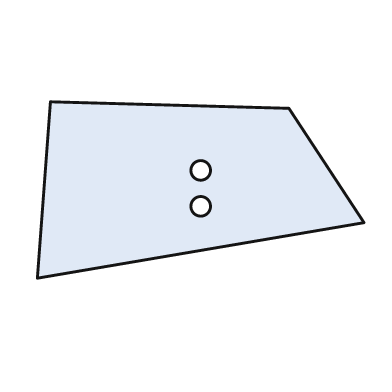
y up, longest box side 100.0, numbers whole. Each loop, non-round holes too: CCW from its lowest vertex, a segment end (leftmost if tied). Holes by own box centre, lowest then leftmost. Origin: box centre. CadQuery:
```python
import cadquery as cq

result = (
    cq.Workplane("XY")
    .moveTo(-50.0, -27.0)
    .lineTo(50.0, -10.0)
    .lineTo(27.0, 25.0)
    .lineTo(-46.0, 27.0)
    .close()
    .moveTo(0.0, -5.0)
    .circle(3.0)
    .moveTo(0.0, 6.0)
    .circle(3.0)
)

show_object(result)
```